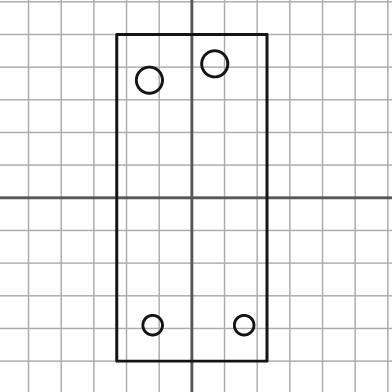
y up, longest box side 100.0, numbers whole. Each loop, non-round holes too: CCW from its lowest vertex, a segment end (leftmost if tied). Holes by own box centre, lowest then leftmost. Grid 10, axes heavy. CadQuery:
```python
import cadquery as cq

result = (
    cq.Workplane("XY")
    .moveTo(-23.0, -50.0)
    .lineTo(23.0, -50.0)
    .lineTo(23.0, 50.0)
    .lineTo(-23.0, 50.0)
    .close()
    .moveTo(-12.0, -39.0)
    .circle(3.0)
    .moveTo(16.0, -39.0)
    .circle(3.0)
    .moveTo(-13.0, 36.0)
    .circle(4.0)
    .moveTo(7.0, 41.0)
    .circle(4.0)
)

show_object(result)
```